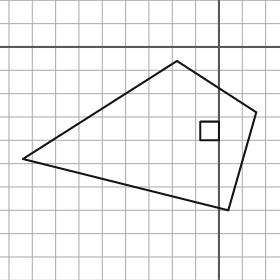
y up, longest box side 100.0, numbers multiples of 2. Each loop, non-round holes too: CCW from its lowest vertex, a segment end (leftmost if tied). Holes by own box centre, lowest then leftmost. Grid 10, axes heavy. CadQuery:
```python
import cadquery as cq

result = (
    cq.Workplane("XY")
    .moveTo(4.0, -70.0)
    .lineTo(16.0, -28.0)
    .lineTo(-18.0, -6.0)
    .lineTo(-84.0, -48.0)
    .close()
    .moveTo(-8.0, -40.0)
    .lineTo(0.0, -40.0)
    .lineTo(0.0, -32.0)
    .lineTo(-8.0, -32.0)
    .close()
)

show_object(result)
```